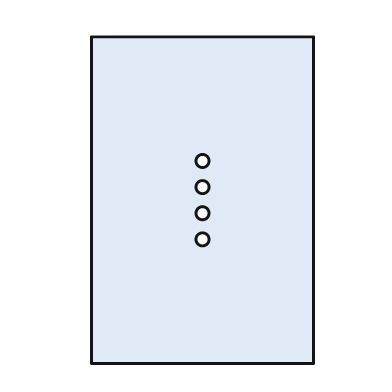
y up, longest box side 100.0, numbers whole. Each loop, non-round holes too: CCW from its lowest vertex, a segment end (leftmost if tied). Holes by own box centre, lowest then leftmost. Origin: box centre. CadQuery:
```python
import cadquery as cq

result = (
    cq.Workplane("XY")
    .moveTo(-34.0, -50.0)
    .lineTo(34.0, -50.0)
    .lineTo(34.0, 50.0)
    .lineTo(-34.0, 50.0)
    .close()
    .moveTo(0.0, -12.0)
    .circle(2.0)
    .moveTo(0.0, -4.0)
    .circle(2.0)
    .moveTo(0.0, 4.0)
    .circle(2.0)
    .moveTo(0.0, 12.0)
    .circle(2.0)
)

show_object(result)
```